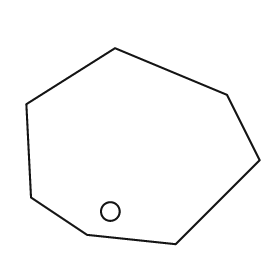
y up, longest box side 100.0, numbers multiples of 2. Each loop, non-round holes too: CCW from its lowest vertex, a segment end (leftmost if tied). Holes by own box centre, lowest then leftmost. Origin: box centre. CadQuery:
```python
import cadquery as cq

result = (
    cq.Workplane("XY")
    .moveTo(14.0, -42.0)
    .lineTo(50.0, -6.0)
    .lineTo(36.0, 22.0)
    .lineTo(-12.0, 42.0)
    .lineTo(-50.0, 18.0)
    .lineTo(-48.0, -22.0)
    .lineTo(-24.0, -38.0)
    .close()
    .moveTo(-14.0, -28.0)
    .circle(4.0)
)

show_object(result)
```